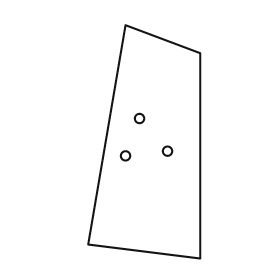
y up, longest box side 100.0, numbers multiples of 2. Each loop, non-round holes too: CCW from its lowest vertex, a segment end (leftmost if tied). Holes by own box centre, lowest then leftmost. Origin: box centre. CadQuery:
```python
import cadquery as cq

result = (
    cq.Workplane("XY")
    .moveTo(24.0, -50.0)
    .lineTo(24.0, 38.0)
    .lineTo(-8.0, 50.0)
    .lineTo(-24.0, -44.0)
    .close()
    .moveTo(-8.0, -6.0)
    .circle(2.0)
    .moveTo(10.0, -4.0)
    .circle(2.0)
    .moveTo(-2.0, 10.0)
    .circle(2.0)
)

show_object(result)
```